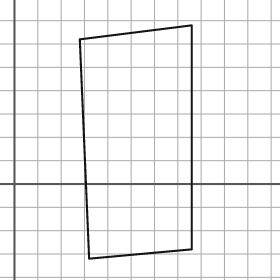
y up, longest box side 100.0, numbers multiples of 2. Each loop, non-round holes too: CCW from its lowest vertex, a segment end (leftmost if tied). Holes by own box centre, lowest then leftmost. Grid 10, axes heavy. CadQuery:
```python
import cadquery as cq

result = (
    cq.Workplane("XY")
    .moveTo(32.0, -32.0)
    .lineTo(76.0, -28.0)
    .lineTo(76.0, 68.0)
    .lineTo(28.0, 62.0)
    .close()
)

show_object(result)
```